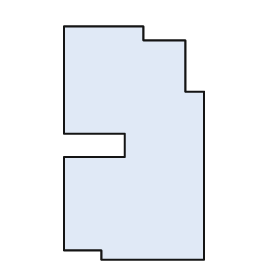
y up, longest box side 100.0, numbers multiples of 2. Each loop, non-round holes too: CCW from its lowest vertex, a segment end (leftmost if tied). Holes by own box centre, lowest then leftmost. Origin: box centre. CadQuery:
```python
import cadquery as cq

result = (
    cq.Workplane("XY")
    .moveTo(-14.0, -50.0)
    .lineTo(30.0, -50.0)
    .lineTo(30.0, 22.0)
    .lineTo(22.0, 22.0)
    .lineTo(22.0, 44.0)
    .lineTo(4.0, 44.0)
    .lineTo(4.0, 50.0)
    .lineTo(-30.0, 50.0)
    .lineTo(-30.0, 4.0)
    .lineTo(-4.0, 4.0)
    .lineTo(-4.0, -6.0)
    .lineTo(-30.0, -6.0)
    .lineTo(-30.0, -46.0)
    .lineTo(-14.0, -46.0)
    .close()
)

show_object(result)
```